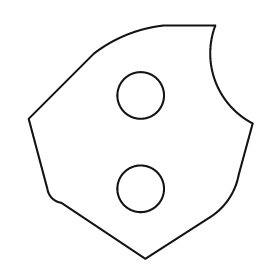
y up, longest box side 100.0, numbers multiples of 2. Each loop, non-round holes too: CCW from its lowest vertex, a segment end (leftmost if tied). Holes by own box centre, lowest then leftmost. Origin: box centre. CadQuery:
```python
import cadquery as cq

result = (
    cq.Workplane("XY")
    .moveTo(2.0, -50.0)
    .lineTo(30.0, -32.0)
    .threePointArc((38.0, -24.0), (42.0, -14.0))
    .lineTo(48.0, 8.0)
    .threePointArc((32.0, 26.0), (32.0, 50.0))
    .lineTo(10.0, 50.0)
    .threePointArc((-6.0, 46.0), (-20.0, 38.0))
    .lineTo(-48.0, 10.0)
    .lineTo(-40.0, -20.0)
    .threePointArc((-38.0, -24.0), (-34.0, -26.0))
    .close()
    .moveTo(0.0, -20.0)
    .circle(10.0)
    .moveTo(0.0, 20.0)
    .circle(10.0)
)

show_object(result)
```